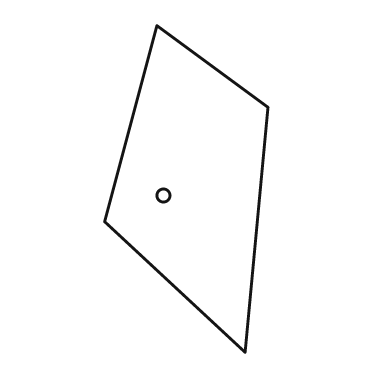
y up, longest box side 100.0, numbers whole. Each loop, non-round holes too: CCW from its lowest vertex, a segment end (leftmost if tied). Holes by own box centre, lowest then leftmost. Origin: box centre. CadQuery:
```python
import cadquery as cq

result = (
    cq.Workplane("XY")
    .moveTo(18.0, -50.0)
    .lineTo(25.0, 25.0)
    .lineTo(-9.0, 50.0)
    .lineTo(-25.0, -10.0)
    .close()
    .moveTo(-7.0, -2.0)
    .circle(2.0)
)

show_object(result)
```